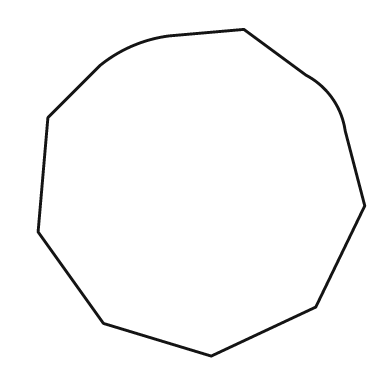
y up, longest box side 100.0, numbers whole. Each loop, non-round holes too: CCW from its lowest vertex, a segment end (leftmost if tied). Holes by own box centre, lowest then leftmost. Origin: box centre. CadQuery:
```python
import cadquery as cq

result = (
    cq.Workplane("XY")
    .moveTo(3.0, -50.0)
    .lineTo(35.0, -35.0)
    .lineTo(50.0, -4.0)
    .lineTo(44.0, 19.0)
    .threePointArc((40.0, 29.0), (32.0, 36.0))
    .lineTo(13.0, 50.0)
    .lineTo(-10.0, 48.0)
    .threePointArc((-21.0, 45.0), (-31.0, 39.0))
    .lineTo(-47.0, 23.0)
    .lineTo(-50.0, -12.0)
    .lineTo(-30.0, -40.0)
    .close()
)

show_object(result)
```